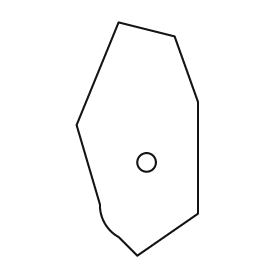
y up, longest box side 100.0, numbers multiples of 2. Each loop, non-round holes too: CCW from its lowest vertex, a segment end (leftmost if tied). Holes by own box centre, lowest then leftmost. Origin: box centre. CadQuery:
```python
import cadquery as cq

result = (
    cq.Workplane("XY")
    .moveTo(0.0, -50.0)
    .lineTo(26.0, -32.0)
    .lineTo(26.0, 16.0)
    .lineTo(16.0, 44.0)
    .lineTo(-8.0, 50.0)
    .lineTo(-26.0, 6.0)
    .lineTo(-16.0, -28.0)
    .threePointArc((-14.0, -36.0), (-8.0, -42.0))
    .close()
    .moveTo(4.0, -10.0)
    .circle(4.0)
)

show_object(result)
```